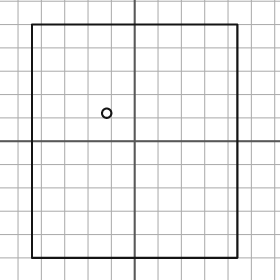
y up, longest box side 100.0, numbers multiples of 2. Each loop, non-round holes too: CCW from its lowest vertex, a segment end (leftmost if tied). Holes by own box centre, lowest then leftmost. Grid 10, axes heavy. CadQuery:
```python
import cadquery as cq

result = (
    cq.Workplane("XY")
    .moveTo(-44.0, -50.0)
    .lineTo(44.0, -50.0)
    .lineTo(44.0, 50.0)
    .lineTo(-44.0, 50.0)
    .close()
    .moveTo(-12.0, 12.0)
    .circle(2.0)
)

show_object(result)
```